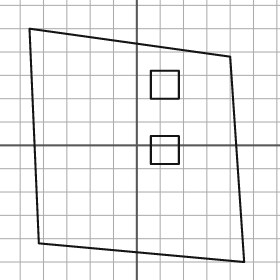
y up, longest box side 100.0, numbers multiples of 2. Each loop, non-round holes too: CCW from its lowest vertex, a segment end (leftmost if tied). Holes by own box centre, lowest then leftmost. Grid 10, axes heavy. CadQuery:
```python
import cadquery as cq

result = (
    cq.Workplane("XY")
    .moveTo(46.0, -50.0)
    .lineTo(40.0, 38.0)
    .lineTo(-46.0, 50.0)
    .lineTo(-42.0, -42.0)
    .close()
    .moveTo(6.0, -8.0)
    .lineTo(18.0, -8.0)
    .lineTo(18.0, 4.0)
    .lineTo(6.0, 4.0)
    .close()
    .moveTo(6.0, 20.0)
    .lineTo(18.0, 20.0)
    .lineTo(18.0, 32.0)
    .lineTo(6.0, 32.0)
    .close()
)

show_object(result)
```